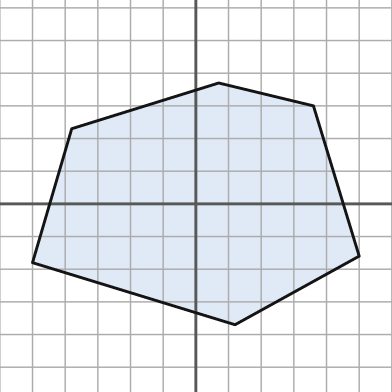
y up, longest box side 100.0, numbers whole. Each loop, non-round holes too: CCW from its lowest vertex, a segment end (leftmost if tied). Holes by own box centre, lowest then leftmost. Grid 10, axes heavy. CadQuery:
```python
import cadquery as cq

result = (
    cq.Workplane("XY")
    .moveTo(12.0, -37.0)
    .lineTo(50.0, -16.0)
    .lineTo(36.0, 30.0)
    .lineTo(7.0, 37.0)
    .lineTo(-38.0, 23.0)
    .lineTo(-50.0, -18.0)
    .close()
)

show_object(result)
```